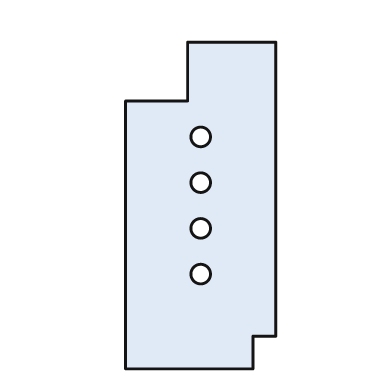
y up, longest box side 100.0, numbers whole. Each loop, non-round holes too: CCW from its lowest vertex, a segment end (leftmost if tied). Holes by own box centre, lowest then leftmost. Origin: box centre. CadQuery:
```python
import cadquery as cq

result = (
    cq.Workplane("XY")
    .moveTo(-23.0, -50.0)
    .lineTo(16.0, -50.0)
    .lineTo(16.0, -40.0)
    .lineTo(23.0, -40.0)
    .lineTo(23.0, 50.0)
    .lineTo(-4.0, 50.0)
    .lineTo(-4.0, 32.0)
    .lineTo(-23.0, 32.0)
    .close()
    .moveTo(0.0, -21.0)
    .circle(3.0)
    .moveTo(0.0, -7.0)
    .circle(3.0)
    .moveTo(0.0, 7.0)
    .circle(3.0)
    .moveTo(0.0, 21.0)
    .circle(3.0)
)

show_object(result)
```